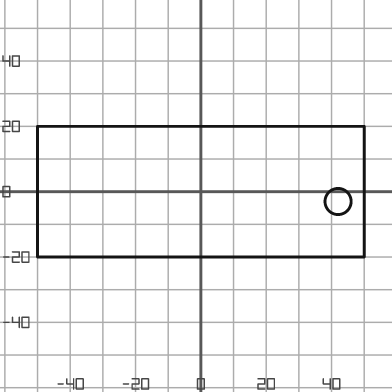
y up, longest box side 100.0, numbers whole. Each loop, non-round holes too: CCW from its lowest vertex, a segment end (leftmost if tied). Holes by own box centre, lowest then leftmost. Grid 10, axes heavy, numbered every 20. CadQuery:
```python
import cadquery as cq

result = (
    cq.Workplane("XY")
    .moveTo(-50.0, -20.0)
    .lineTo(50.0, -20.0)
    .lineTo(50.0, 20.0)
    .lineTo(-50.0, 20.0)
    .close()
    .moveTo(42.0, -3.0)
    .circle(4.0)
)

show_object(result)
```